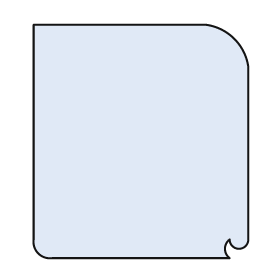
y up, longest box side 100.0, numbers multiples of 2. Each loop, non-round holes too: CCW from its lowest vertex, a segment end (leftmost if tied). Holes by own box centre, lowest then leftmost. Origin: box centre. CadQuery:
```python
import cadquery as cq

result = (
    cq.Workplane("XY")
    .moveTo(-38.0, -50.0)
    .lineTo(38.0, -50.0)
    .threePointArc((36.0, -46.0), (38.0, -42.0))
    .threePointArc((42.0, -46.0), (46.0, -42.0))
    .lineTo(46.0, 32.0)
    .threePointArc((40.0, 44.0), (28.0, 50.0))
    .lineTo(-46.0, 50.0)
    .lineTo(-46.0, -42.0)
    .threePointArc((-44.0, -48.0), (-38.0, -50.0))
    .close()
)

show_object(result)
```